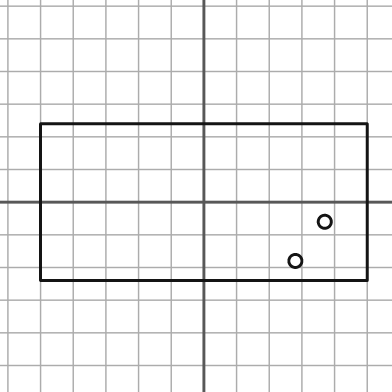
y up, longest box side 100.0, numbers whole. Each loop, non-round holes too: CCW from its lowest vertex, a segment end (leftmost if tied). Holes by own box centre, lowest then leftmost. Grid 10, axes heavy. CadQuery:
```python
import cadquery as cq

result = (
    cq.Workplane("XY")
    .moveTo(-50.0, -24.0)
    .lineTo(50.0, -24.0)
    .lineTo(50.0, 24.0)
    .lineTo(-50.0, 24.0)
    .close()
    .moveTo(28.0, -18.0)
    .circle(2.0)
    .moveTo(37.0, -6.0)
    .circle(2.0)
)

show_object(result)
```